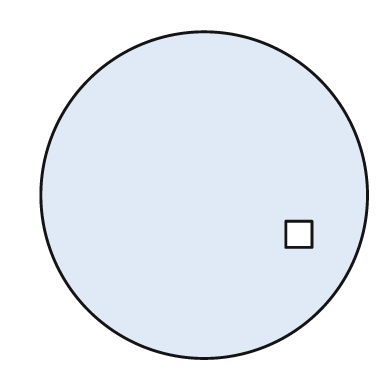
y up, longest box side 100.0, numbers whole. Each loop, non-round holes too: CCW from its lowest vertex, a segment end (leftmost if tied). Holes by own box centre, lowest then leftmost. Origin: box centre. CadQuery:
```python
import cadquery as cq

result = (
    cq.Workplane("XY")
    .moveTo(0.0, 0.0)
    .circle(50.0)
    .moveTo(25.0, -16.0)
    .lineTo(33.0, -16.0)
    .lineTo(33.0, -8.0)
    .lineTo(25.0, -8.0)
    .close()
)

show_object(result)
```